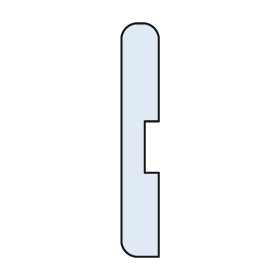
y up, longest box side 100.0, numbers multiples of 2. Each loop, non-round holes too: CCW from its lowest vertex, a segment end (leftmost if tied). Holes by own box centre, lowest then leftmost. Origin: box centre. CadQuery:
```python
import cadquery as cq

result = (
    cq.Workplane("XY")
    .moveTo(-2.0, -50.0)
    .lineTo(8.0, -50.0)
    .lineTo(8.0, -14.0)
    .lineTo(2.0, -14.0)
    .lineTo(2.0, 8.0)
    .lineTo(8.0, 8.0)
    .lineTo(8.0, 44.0)
    .threePointArc((6.0, 48.0), (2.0, 50.0))
    .lineTo(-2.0, 50.0)
    .threePointArc((-6.0, 48.0), (-8.0, 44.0))
    .lineTo(-8.0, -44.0)
    .threePointArc((-6.0, -48.0), (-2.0, -50.0))
    .close()
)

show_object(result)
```